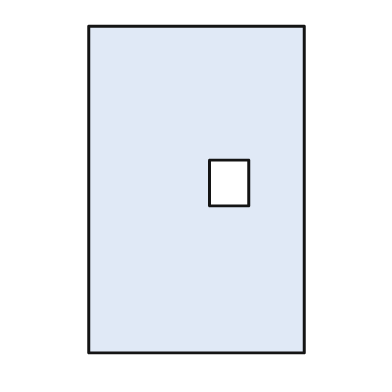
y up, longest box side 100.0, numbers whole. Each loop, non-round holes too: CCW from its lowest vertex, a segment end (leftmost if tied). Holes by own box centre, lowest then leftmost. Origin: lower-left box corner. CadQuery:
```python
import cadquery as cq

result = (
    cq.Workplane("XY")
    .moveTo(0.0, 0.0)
    .lineTo(66.0, 0.0)
    .lineTo(66.0, 100.0)
    .lineTo(0.0, 100.0)
    .close()
    .moveTo(37.0, 45.0)
    .lineTo(49.0, 45.0)
    .lineTo(49.0, 59.0)
    .lineTo(37.0, 59.0)
    .close()
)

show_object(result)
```